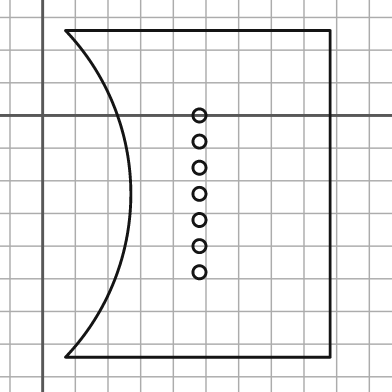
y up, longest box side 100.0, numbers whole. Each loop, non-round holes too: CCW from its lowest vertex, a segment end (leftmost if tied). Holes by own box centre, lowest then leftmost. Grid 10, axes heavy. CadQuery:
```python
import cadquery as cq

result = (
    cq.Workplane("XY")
    .moveTo(7.0, -74.0)
    .lineTo(88.0, -74.0)
    .lineTo(88.0, 26.0)
    .lineTo(7.0, 26.0)
    .threePointArc((27.0, -24.0), (7.0, -74.0))
    .close()
    .moveTo(48.0, -48.0)
    .circle(2.0)
    .moveTo(48.0, -40.0)
    .circle(2.0)
    .moveTo(48.0, -32.0)
    .circle(2.0)
    .moveTo(48.0, -24.0)
    .circle(2.0)
    .moveTo(48.0, -16.0)
    .circle(2.0)
    .moveTo(48.0, -8.0)
    .circle(2.0)
    .moveTo(48.0, 0.0)
    .circle(2.0)
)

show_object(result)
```